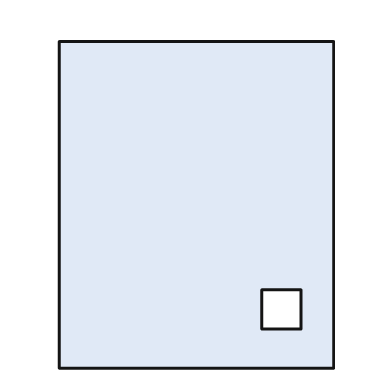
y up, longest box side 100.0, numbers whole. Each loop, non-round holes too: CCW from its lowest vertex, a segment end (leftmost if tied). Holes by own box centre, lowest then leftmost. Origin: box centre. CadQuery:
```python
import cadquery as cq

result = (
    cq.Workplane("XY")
    .moveTo(-42.0, -50.0)
    .lineTo(42.0, -50.0)
    .lineTo(42.0, 50.0)
    .lineTo(-42.0, 50.0)
    .close()
    .moveTo(20.0, -38.0)
    .lineTo(32.0, -38.0)
    .lineTo(32.0, -26.0)
    .lineTo(20.0, -26.0)
    .close()
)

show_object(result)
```